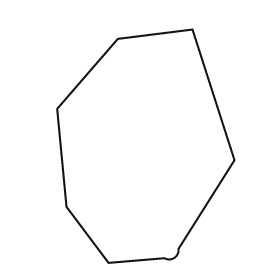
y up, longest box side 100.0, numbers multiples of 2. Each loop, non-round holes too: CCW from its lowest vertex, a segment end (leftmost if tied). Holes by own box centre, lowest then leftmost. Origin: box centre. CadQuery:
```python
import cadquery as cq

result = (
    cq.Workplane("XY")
    .moveTo(-16.0, -50.0)
    .lineTo(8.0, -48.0)
    .threePointArc((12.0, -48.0), (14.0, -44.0))
    .lineTo(38.0, -6.0)
    .lineTo(20.0, 50.0)
    .lineTo(-12.0, 46.0)
    .lineTo(-38.0, 16.0)
    .lineTo(-34.0, -26.0)
    .close()
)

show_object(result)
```